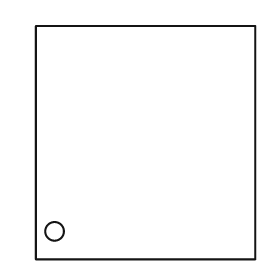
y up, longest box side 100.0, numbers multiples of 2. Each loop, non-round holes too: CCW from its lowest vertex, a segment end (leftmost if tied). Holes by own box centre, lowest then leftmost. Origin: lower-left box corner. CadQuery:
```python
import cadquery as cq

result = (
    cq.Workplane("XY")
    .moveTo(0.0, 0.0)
    .lineTo(94.0, 0.0)
    .lineTo(94.0, 100.0)
    .lineTo(0.0, 100.0)
    .close()
    .moveTo(8.0, 12.0)
    .circle(4.0)
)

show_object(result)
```